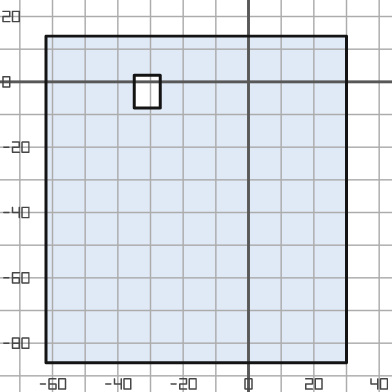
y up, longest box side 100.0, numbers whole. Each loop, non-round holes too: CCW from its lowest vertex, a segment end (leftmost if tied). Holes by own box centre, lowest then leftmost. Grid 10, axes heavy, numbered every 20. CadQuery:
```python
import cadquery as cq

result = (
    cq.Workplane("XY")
    .moveTo(-62.0, -86.0)
    .lineTo(30.0, -86.0)
    .lineTo(30.0, 14.0)
    .lineTo(-62.0, 14.0)
    .close()
    .moveTo(-35.0, -8.0)
    .lineTo(-27.0, -8.0)
    .lineTo(-27.0, 2.0)
    .lineTo(-35.0, 2.0)
    .close()
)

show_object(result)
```